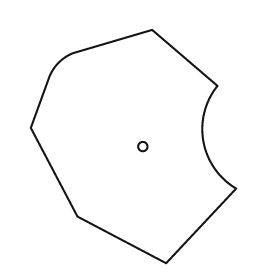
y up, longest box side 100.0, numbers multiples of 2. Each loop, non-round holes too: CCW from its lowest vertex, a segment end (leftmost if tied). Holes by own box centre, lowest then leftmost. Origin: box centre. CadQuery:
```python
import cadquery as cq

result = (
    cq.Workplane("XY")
    .moveTo(14.0, -50.0)
    .lineTo(44.0, -18.0)
    .threePointArc((30.0, 2.0), (36.0, 26.0))
    .lineTo(8.0, 50.0)
    .lineTo(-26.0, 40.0)
    .threePointArc((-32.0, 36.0), (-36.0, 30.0))
    .lineTo(-44.0, 8.0)
    .lineTo(-24.0, -30.0)
    .close()
    .moveTo(4.0, 0.0)
    .circle(2.0)
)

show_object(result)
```